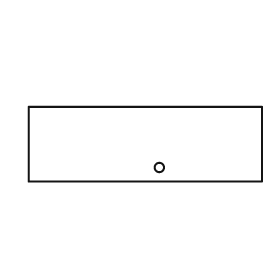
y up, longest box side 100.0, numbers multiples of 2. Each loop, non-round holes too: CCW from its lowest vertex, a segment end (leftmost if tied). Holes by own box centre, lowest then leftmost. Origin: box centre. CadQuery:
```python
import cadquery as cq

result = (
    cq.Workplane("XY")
    .moveTo(-50.0, -16.0)
    .lineTo(50.0, -16.0)
    .lineTo(50.0, 16.0)
    .lineTo(-50.0, 16.0)
    .close()
    .moveTo(6.0, -10.0)
    .circle(2.0)
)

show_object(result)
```